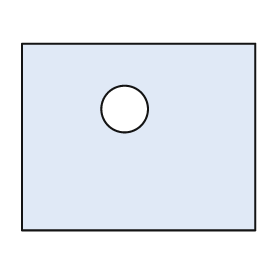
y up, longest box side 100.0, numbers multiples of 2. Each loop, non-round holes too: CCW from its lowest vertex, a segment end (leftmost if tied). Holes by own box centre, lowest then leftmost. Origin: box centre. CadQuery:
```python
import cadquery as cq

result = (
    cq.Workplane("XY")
    .moveTo(-50.0, -40.0)
    .lineTo(50.0, -40.0)
    .lineTo(50.0, 40.0)
    .lineTo(-50.0, 40.0)
    .close()
    .moveTo(-6.0, 12.0)
    .circle(10.0)
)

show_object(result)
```